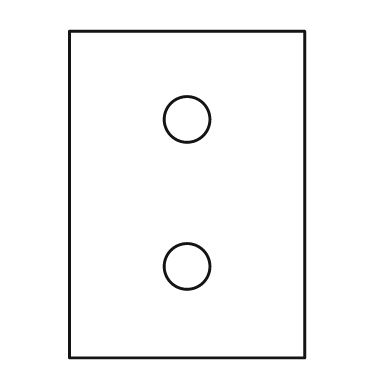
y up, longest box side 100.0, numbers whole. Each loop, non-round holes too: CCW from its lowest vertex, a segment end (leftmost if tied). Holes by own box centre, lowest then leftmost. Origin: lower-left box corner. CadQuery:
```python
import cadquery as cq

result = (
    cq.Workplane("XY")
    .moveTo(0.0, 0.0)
    .lineTo(72.0, 0.0)
    .lineTo(72.0, 100.0)
    .lineTo(0.0, 100.0)
    .close()
    .moveTo(36.0, 28.0)
    .circle(7.0)
    .moveTo(36.0, 73.0)
    .circle(7.0)
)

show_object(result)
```